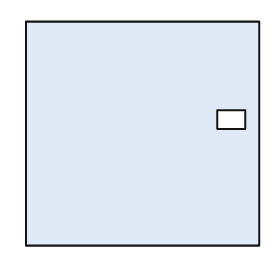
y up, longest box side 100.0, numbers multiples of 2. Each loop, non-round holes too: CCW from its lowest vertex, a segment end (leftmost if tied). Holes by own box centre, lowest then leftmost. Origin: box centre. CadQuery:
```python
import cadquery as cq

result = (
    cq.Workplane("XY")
    .moveTo(-50.0, -48.0)
    .lineTo(50.0, -48.0)
    .lineTo(50.0, 48.0)
    .lineTo(-50.0, 48.0)
    .close()
    .moveTo(32.0, 2.0)
    .lineTo(44.0, 2.0)
    .lineTo(44.0, 10.0)
    .lineTo(32.0, 10.0)
    .close()
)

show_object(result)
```